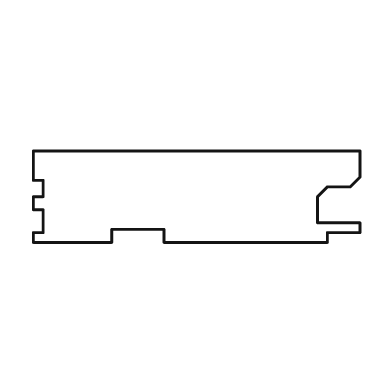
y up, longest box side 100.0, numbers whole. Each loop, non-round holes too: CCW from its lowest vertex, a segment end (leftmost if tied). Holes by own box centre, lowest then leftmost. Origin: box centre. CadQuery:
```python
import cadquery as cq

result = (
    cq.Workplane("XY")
    .moveTo(-50.0, -14.0)
    .lineTo(-26.0, -14.0)
    .lineTo(-26.0, -10.0)
    .lineTo(-10.0, -10.0)
    .lineTo(-10.0, -14.0)
    .lineTo(40.0, -14.0)
    .lineTo(40.0, -11.0)
    .lineTo(50.0, -11.0)
    .lineTo(50.0, -8.0)
    .lineTo(37.0, -8.0)
    .lineTo(37.0, 0.0)
    .lineTo(40.0, 3.0)
    .lineTo(47.0, 3.0)
    .lineTo(50.0, 6.0)
    .lineTo(50.0, 14.0)
    .lineTo(-50.0, 14.0)
    .lineTo(-50.0, 5.0)
    .lineTo(-47.0, 5.0)
    .lineTo(-47.0, 0.0)
    .lineTo(-50.0, 0.0)
    .lineTo(-50.0, -4.0)
    .lineTo(-47.0, -4.0)
    .lineTo(-47.0, -11.0)
    .lineTo(-50.0, -11.0)
    .close()
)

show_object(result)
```